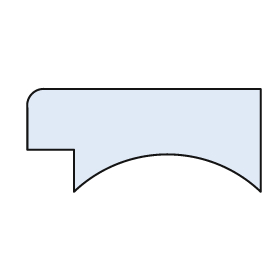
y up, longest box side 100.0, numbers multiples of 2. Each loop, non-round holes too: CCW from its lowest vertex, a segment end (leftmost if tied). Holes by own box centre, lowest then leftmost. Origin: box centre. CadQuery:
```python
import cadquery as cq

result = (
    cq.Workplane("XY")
    .moveTo(-30.0, -22.0)
    .threePointArc((10.0, -6.0), (50.0, -22.0))
    .lineTo(50.0, 22.0)
    .lineTo(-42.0, 22.0)
    .threePointArc((-48.0, 20.0), (-50.0, 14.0))
    .lineTo(-50.0, -4.0)
    .lineTo(-30.0, -4.0)
    .close()
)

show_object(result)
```